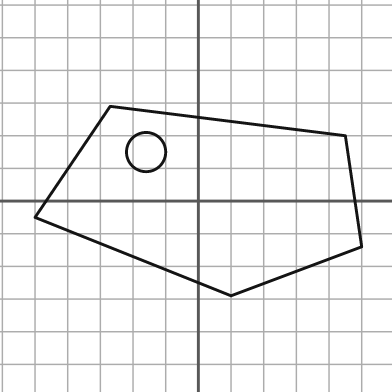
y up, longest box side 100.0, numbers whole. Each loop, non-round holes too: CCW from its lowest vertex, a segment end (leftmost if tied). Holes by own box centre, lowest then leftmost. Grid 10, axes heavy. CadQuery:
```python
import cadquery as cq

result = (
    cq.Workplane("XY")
    .moveTo(10.0, -29.0)
    .lineTo(50.0, -14.0)
    .lineTo(45.0, 20.0)
    .lineTo(-27.0, 29.0)
    .lineTo(-50.0, -5.0)
    .close()
    .moveTo(-16.0, 15.0)
    .circle(6.0)
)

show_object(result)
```